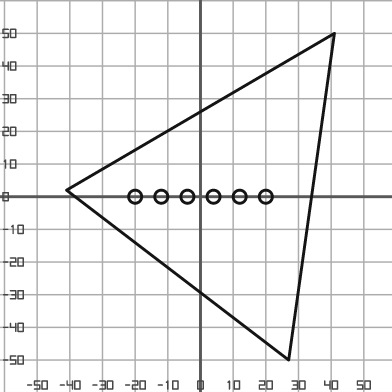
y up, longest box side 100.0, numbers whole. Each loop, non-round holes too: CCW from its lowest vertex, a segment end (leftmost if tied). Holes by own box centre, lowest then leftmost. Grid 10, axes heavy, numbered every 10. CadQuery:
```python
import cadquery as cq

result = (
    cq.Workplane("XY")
    .moveTo(27.0, -50.0)
    .lineTo(41.0, 50.0)
    .lineTo(-41.0, 2.0)
    .close()
    .moveTo(-20.0, 0.0)
    .circle(2.0)
    .moveTo(-12.0, 0.0)
    .circle(2.0)
    .moveTo(-4.0, 0.0)
    .circle(2.0)
    .moveTo(4.0, 0.0)
    .circle(2.0)
    .moveTo(12.0, 0.0)
    .circle(2.0)
    .moveTo(20.0, 0.0)
    .circle(2.0)
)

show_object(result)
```